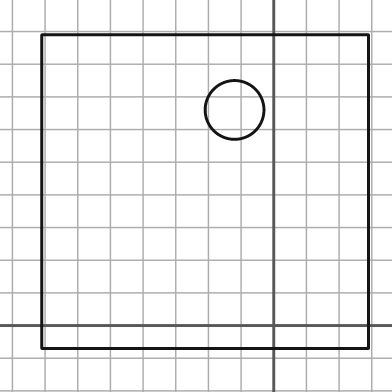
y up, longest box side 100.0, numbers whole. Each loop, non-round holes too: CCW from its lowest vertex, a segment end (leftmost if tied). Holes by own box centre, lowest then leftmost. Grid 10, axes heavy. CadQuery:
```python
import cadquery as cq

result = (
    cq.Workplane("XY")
    .moveTo(-71.0, -7.0)
    .lineTo(29.0, -7.0)
    .lineTo(29.0, 89.0)
    .lineTo(-71.0, 89.0)
    .close()
    .moveTo(-12.0, 66.0)
    .circle(9.0)
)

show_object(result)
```